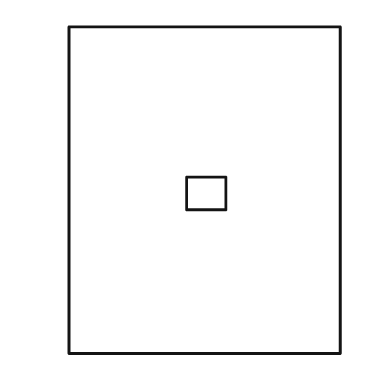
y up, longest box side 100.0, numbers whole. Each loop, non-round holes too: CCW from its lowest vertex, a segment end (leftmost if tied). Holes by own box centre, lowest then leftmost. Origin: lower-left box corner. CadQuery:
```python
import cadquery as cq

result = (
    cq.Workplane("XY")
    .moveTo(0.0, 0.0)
    .lineTo(83.0, 0.0)
    .lineTo(83.0, 100.0)
    .lineTo(0.0, 100.0)
    .close()
    .moveTo(36.0, 44.0)
    .lineTo(48.0, 44.0)
    .lineTo(48.0, 54.0)
    .lineTo(36.0, 54.0)
    .close()
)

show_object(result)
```